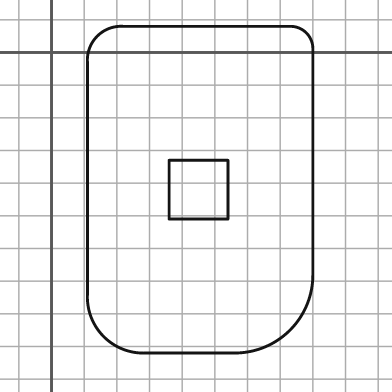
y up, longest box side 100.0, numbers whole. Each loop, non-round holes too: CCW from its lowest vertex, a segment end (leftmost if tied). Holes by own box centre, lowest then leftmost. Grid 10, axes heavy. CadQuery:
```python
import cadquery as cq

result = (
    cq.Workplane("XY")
    .moveTo(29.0, -92.0)
    .lineTo(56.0, -92.0)
    .threePointArc((73.0, -85.0), (80.0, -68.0))
    .lineTo(80.0, 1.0)
    .threePointArc((78.0, 6.0), (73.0, 8.0))
    .lineTo(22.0, 8.0)
    .threePointArc((14.0, 5.0), (11.0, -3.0))
    .lineTo(11.0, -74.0)
    .threePointArc((16.0, -87.0), (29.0, -92.0))
    .close()
    .moveTo(36.0, -51.0)
    .lineTo(54.0, -51.0)
    .lineTo(54.0, -33.0)
    .lineTo(36.0, -33.0)
    .close()
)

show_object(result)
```